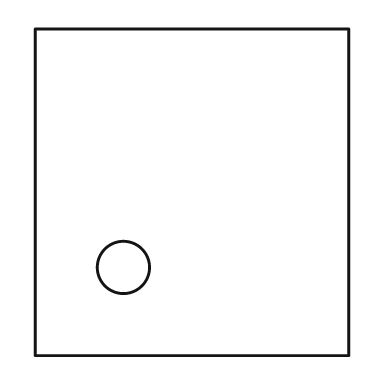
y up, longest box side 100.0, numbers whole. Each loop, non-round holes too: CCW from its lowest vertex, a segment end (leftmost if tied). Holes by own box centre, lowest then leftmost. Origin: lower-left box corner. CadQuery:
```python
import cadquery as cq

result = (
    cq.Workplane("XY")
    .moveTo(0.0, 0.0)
    .lineTo(96.0, 0.0)
    .lineTo(96.0, 100.0)
    .lineTo(0.0, 100.0)
    .close()
    .moveTo(27.0, 27.0)
    .circle(8.0)
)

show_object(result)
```